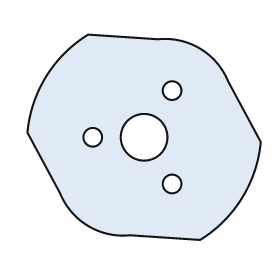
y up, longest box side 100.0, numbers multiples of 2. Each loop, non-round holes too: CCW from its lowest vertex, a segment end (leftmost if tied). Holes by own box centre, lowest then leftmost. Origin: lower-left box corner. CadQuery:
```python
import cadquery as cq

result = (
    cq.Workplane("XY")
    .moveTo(74.0, 0.0)
    .threePointArc((92.0, 18.0), (100.0, 42.0))
    .lineTo(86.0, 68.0)
    .threePointArc((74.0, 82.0), (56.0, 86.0))
    .lineTo(26.0, 88.0)
    .threePointArc((8.0, 70.0), (0.0, 46.0))
    .lineTo(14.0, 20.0)
    .threePointArc((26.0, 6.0), (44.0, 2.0))
    .close()
    .moveTo(62.0, 24.0)
    .circle(4.0)
    .moveTo(28.0, 44.0)
    .circle(4.0)
    .moveTo(50.0, 44.0)
    .circle(10.0)
    .moveTo(62.0, 64.0)
    .circle(4.0)
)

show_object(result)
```